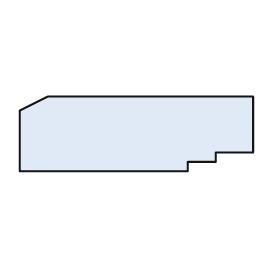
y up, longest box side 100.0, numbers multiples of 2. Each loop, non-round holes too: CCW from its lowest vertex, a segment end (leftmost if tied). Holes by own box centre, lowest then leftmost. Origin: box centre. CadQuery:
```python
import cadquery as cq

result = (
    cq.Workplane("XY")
    .moveTo(-50.0, -16.0)
    .lineTo(22.0, -16.0)
    .lineTo(22.0, -12.0)
    .lineTo(34.0, -12.0)
    .lineTo(34.0, -8.0)
    .lineTo(50.0, -8.0)
    .lineTo(50.0, 16.0)
    .lineTo(-38.0, 16.0)
    .lineTo(-50.0, 10.0)
    .close()
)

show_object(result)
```